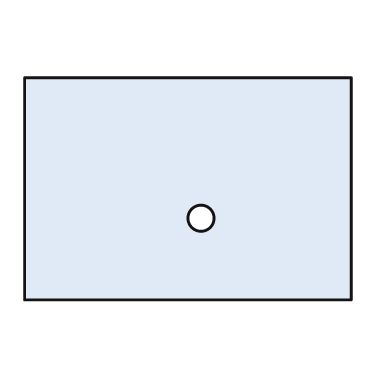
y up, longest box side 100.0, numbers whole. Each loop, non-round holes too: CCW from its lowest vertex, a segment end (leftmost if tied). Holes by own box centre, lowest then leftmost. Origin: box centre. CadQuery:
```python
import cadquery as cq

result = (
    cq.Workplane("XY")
    .moveTo(-50.0, -34.0)
    .lineTo(50.0, -34.0)
    .lineTo(50.0, 34.0)
    .lineTo(-50.0, 34.0)
    .close()
    .moveTo(4.0, -9.0)
    .circle(4.0)
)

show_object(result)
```